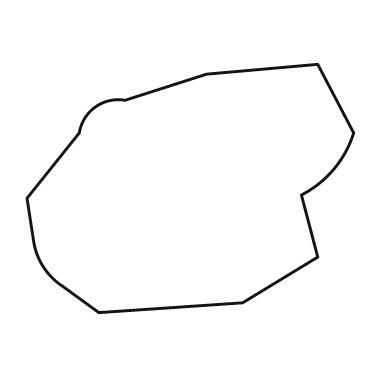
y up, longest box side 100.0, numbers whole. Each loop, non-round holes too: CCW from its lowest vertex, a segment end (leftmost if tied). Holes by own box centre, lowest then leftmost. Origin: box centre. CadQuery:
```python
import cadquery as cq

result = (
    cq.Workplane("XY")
    .moveTo(-28.0, -38.0)
    .lineTo(16.0, -35.0)
    .lineTo(39.0, -21.0)
    .lineTo(34.0, -2.0)
    .threePointArc((44.0, 6.0), (50.0, 17.0))
    .lineTo(39.0, 38.0)
    .lineTo(5.0, 35.0)
    .lineTo(-20.0, 27.0)
    .threePointArc((-29.0, 25.0), (-34.0, 17.0))
    .lineTo(-50.0, -3.0)
    .lineTo(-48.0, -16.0)
    .threePointArc((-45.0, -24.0), (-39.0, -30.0))
    .close()
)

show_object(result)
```